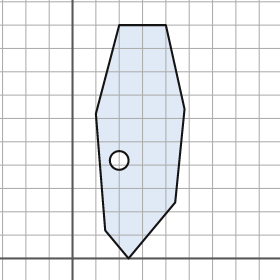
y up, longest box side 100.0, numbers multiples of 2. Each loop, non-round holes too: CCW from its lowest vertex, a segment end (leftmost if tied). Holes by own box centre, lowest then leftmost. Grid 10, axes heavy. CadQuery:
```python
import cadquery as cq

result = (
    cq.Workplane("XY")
    .moveTo(24.0, 0.0)
    .lineTo(44.0, 24.0)
    .lineTo(48.0, 64.0)
    .lineTo(40.0, 100.0)
    .lineTo(20.0, 100.0)
    .lineTo(10.0, 62.0)
    .lineTo(14.0, 12.0)
    .close()
    .moveTo(20.0, 42.0)
    .circle(4.0)
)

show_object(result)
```